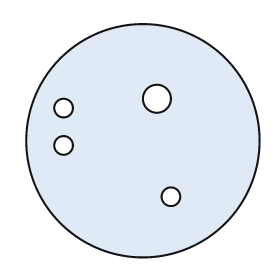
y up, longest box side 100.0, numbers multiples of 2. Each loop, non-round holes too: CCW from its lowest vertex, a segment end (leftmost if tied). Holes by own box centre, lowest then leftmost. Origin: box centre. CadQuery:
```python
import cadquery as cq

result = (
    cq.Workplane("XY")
    .moveTo(0.0, 0.0)
    .circle(50.0)
    .moveTo(12.0, -24.0)
    .circle(4.0)
    .moveTo(-34.0, -2.0)
    .circle(4.0)
    .moveTo(-34.0, 14.0)
    .circle(4.0)
    .moveTo(6.0, 18.0)
    .circle(6.0)
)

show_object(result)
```